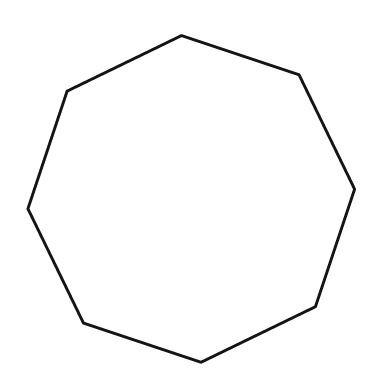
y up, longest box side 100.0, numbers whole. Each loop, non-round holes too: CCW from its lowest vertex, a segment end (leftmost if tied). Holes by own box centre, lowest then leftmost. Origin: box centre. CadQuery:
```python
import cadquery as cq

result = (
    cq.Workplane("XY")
    .moveTo(3.0, -50.0)
    .lineTo(38.0, -33.0)
    .lineTo(50.0, 3.0)
    .lineTo(33.0, 38.0)
    .lineTo(-3.0, 50.0)
    .lineTo(-38.0, 33.0)
    .lineTo(-50.0, -3.0)
    .lineTo(-33.0, -38.0)
    .close()
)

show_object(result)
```